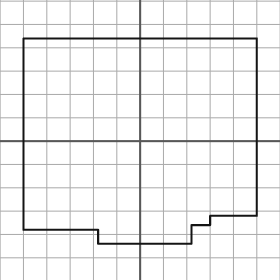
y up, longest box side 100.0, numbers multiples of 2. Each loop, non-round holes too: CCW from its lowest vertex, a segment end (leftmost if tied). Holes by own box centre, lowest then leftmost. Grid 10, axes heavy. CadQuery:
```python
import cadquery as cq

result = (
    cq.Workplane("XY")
    .moveTo(-18.0, -44.0)
    .lineTo(22.0, -44.0)
    .lineTo(22.0, -36.0)
    .lineTo(30.0, -36.0)
    .lineTo(30.0, -32.0)
    .lineTo(50.0, -32.0)
    .lineTo(50.0, 44.0)
    .lineTo(-50.0, 44.0)
    .lineTo(-50.0, -38.0)
    .lineTo(-18.0, -38.0)
    .close()
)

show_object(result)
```